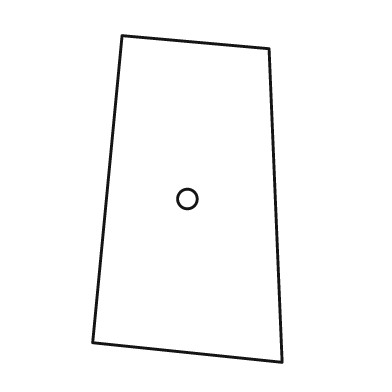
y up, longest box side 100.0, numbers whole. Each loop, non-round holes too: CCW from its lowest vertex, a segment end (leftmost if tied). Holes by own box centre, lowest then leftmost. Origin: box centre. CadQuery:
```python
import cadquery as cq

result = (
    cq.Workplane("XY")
    .moveTo(29.0, -50.0)
    .lineTo(25.0, 46.0)
    .lineTo(-20.0, 50.0)
    .lineTo(-29.0, -44.0)
    .close()
    .moveTo(0.0, 0.0)
    .circle(3.0)
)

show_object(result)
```